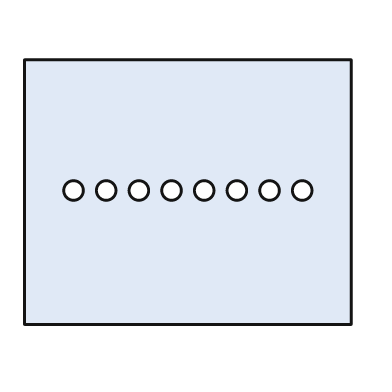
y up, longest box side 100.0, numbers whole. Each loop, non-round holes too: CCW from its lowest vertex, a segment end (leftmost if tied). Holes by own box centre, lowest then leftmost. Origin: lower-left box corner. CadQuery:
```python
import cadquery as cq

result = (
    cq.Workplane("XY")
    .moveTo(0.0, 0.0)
    .lineTo(100.0, 0.0)
    .lineTo(100.0, 81.0)
    .lineTo(0.0, 81.0)
    .close()
    .moveTo(15.0, 41.0)
    .circle(3.0)
    .moveTo(25.0, 41.0)
    .circle(3.0)
    .moveTo(35.0, 41.0)
    .circle(3.0)
    .moveTo(45.0, 41.0)
    .circle(3.0)
    .moveTo(55.0, 41.0)
    .circle(3.0)
    .moveTo(65.0, 41.0)
    .circle(3.0)
    .moveTo(75.0, 41.0)
    .circle(3.0)
    .moveTo(85.0, 41.0)
    .circle(3.0)
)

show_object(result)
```